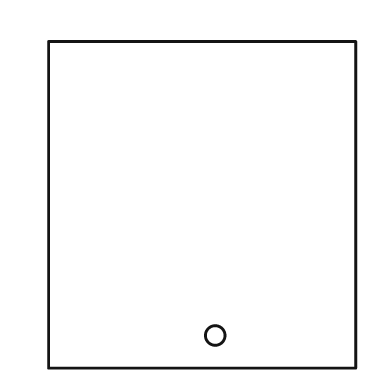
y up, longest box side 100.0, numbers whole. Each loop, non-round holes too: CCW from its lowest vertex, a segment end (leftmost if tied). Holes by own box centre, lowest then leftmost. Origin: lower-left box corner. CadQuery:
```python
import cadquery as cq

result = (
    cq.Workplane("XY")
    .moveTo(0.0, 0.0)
    .lineTo(94.0, 0.0)
    .lineTo(94.0, 100.0)
    .lineTo(0.0, 100.0)
    .close()
    .moveTo(51.0, 10.0)
    .circle(3.0)
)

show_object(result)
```